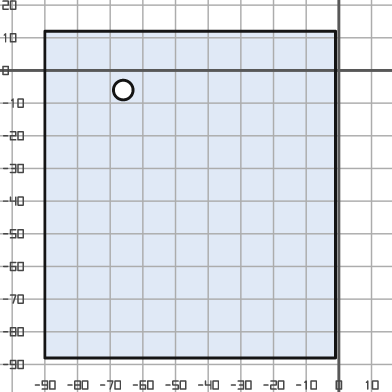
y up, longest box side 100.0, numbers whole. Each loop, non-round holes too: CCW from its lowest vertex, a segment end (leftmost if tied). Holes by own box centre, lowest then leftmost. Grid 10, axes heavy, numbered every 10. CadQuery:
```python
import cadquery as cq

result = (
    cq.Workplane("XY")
    .moveTo(-90.0, -88.0)
    .lineTo(-1.0, -88.0)
    .lineTo(-1.0, 12.0)
    .lineTo(-90.0, 12.0)
    .close()
    .moveTo(-66.0, -6.0)
    .circle(3.0)
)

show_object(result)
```